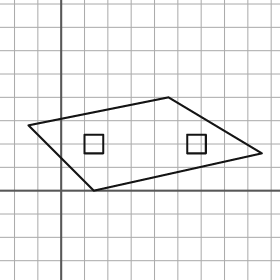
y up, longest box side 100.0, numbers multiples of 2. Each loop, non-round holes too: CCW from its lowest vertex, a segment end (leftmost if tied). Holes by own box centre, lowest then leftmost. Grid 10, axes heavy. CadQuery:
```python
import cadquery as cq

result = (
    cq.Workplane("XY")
    .moveTo(14.0, 0.0)
    .lineTo(86.0, 16.0)
    .lineTo(46.0, 40.0)
    .lineTo(-14.0, 28.0)
    .close()
    .moveTo(10.0, 16.0)
    .lineTo(18.0, 16.0)
    .lineTo(18.0, 24.0)
    .lineTo(10.0, 24.0)
    .close()
    .moveTo(54.0, 16.0)
    .lineTo(62.0, 16.0)
    .lineTo(62.0, 24.0)
    .lineTo(54.0, 24.0)
    .close()
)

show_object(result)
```